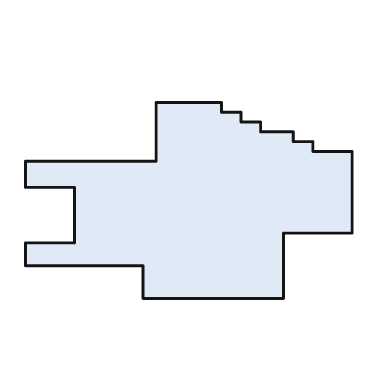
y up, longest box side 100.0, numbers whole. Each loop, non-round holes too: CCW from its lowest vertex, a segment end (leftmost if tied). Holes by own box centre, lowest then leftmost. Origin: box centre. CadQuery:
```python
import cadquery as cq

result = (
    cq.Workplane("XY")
    .moveTo(-14.0, -30.0)
    .lineTo(29.0, -30.0)
    .lineTo(29.0, -10.0)
    .lineTo(50.0, -10.0)
    .lineTo(50.0, 15.0)
    .lineTo(38.0, 15.0)
    .lineTo(38.0, 18.0)
    .lineTo(32.0, 18.0)
    .lineTo(32.0, 21.0)
    .lineTo(22.0, 21.0)
    .lineTo(22.0, 24.0)
    .lineTo(16.0, 24.0)
    .lineTo(16.0, 27.0)
    .lineTo(10.0, 27.0)
    .lineTo(10.0, 30.0)
    .lineTo(-10.0, 30.0)
    .lineTo(-10.0, 12.0)
    .lineTo(-50.0, 12.0)
    .lineTo(-50.0, 4.0)
    .lineTo(-35.0, 4.0)
    .lineTo(-35.0, -13.0)
    .lineTo(-50.0, -13.0)
    .lineTo(-50.0, -20.0)
    .lineTo(-14.0, -20.0)
    .close()
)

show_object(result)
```